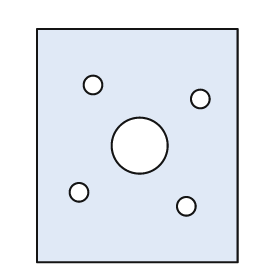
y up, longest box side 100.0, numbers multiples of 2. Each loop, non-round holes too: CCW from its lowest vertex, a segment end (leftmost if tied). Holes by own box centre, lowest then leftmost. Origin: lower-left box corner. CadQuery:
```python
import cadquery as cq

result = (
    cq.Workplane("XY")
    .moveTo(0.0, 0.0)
    .lineTo(86.0, 0.0)
    .lineTo(86.0, 100.0)
    .lineTo(0.0, 100.0)
    .close()
    .moveTo(64.0, 24.0)
    .circle(4.0)
    .moveTo(18.0, 30.0)
    .circle(4.0)
    .moveTo(44.0, 50.0)
    .circle(12.0)
    .moveTo(70.0, 70.0)
    .circle(4.0)
    .moveTo(24.0, 76.0)
    .circle(4.0)
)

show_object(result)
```